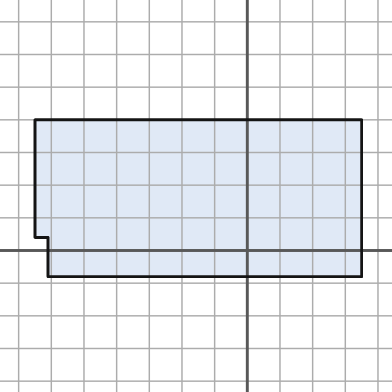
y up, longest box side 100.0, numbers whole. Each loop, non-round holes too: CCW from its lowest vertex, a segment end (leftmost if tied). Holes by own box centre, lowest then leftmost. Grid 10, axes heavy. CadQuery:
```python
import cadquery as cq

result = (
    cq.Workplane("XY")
    .moveTo(-61.0, -8.0)
    .lineTo(35.0, -8.0)
    .lineTo(35.0, 40.0)
    .lineTo(-65.0, 40.0)
    .lineTo(-65.0, 4.0)
    .lineTo(-61.0, 4.0)
    .close()
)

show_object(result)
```